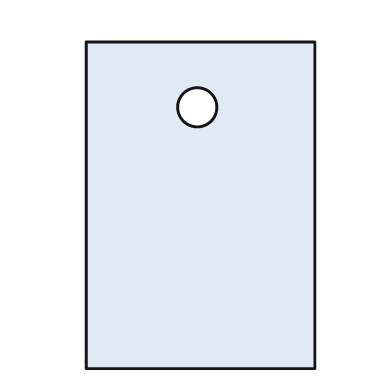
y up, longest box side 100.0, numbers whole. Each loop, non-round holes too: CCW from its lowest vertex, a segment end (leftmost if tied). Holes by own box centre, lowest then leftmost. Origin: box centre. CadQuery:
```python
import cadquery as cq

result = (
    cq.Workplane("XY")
    .moveTo(-35.0, -50.0)
    .lineTo(35.0, -50.0)
    .lineTo(35.0, 50.0)
    .lineTo(-35.0, 50.0)
    .close()
    .moveTo(-1.0, 30.0)
    .circle(6.0)
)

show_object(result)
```